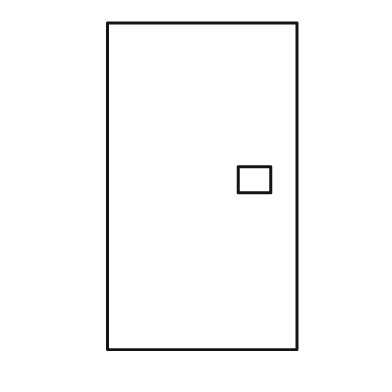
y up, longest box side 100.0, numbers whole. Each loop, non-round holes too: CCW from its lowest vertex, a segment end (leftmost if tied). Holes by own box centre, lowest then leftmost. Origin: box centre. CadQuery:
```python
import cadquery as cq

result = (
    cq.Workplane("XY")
    .moveTo(-29.0, -50.0)
    .lineTo(29.0, -50.0)
    .lineTo(29.0, 50.0)
    .lineTo(-29.0, 50.0)
    .close()
    .moveTo(11.0, -2.0)
    .lineTo(21.0, -2.0)
    .lineTo(21.0, 6.0)
    .lineTo(11.0, 6.0)
    .close()
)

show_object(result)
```